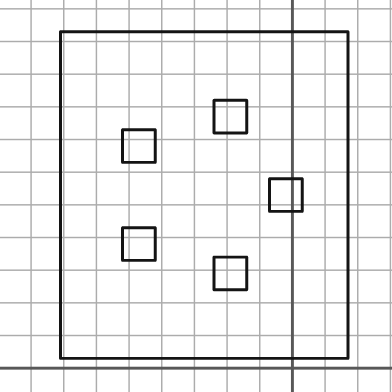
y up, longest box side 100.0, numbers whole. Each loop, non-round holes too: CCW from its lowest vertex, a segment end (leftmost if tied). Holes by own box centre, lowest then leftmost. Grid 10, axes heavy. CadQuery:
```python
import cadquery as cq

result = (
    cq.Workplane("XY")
    .moveTo(-71.0, 3.0)
    .lineTo(17.0, 3.0)
    .lineTo(17.0, 103.0)
    .lineTo(-71.0, 103.0)
    .close()
    .moveTo(-24.0, 24.0)
    .lineTo(-14.0, 24.0)
    .lineTo(-14.0, 34.0)
    .lineTo(-24.0, 34.0)
    .close()
    .moveTo(-52.0, 33.0)
    .lineTo(-42.0, 33.0)
    .lineTo(-42.0, 43.0)
    .lineTo(-52.0, 43.0)
    .close()
    .moveTo(-7.0, 48.0)
    .lineTo(3.0, 48.0)
    .lineTo(3.0, 58.0)
    .lineTo(-7.0, 58.0)
    .close()
    .moveTo(-52.0, 63.0)
    .lineTo(-42.0, 63.0)
    .lineTo(-42.0, 73.0)
    .lineTo(-52.0, 73.0)
    .close()
    .moveTo(-24.0, 72.0)
    .lineTo(-14.0, 72.0)
    .lineTo(-14.0, 82.0)
    .lineTo(-24.0, 82.0)
    .close()
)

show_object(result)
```